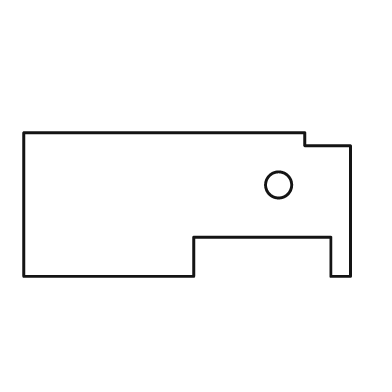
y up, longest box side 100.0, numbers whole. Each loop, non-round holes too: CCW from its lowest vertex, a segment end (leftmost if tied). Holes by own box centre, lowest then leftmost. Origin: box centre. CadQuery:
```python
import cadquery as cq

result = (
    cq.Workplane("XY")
    .moveTo(-50.0, -22.0)
    .lineTo(2.0, -22.0)
    .lineTo(2.0, -10.0)
    .lineTo(44.0, -10.0)
    .lineTo(44.0, -22.0)
    .lineTo(50.0, -22.0)
    .lineTo(50.0, 18.0)
    .lineTo(36.0, 18.0)
    .lineTo(36.0, 22.0)
    .lineTo(-50.0, 22.0)
    .close()
    .moveTo(28.0, 6.0)
    .circle(4.0)
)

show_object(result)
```